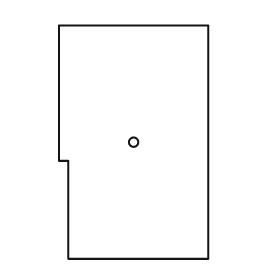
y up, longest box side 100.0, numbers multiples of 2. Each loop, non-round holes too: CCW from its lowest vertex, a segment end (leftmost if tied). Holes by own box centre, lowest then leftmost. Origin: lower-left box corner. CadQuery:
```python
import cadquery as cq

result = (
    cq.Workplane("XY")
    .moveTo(4.0, 0.0)
    .lineTo(64.0, 0.0)
    .lineTo(64.0, 100.0)
    .lineTo(0.0, 100.0)
    .lineTo(0.0, 42.0)
    .lineTo(4.0, 42.0)
    .close()
    .moveTo(32.0, 50.0)
    .circle(2.0)
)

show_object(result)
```